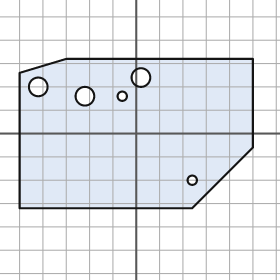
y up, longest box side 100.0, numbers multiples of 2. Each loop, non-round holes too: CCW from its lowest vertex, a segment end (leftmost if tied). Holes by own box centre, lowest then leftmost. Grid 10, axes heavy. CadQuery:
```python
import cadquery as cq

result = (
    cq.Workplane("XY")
    .moveTo(-50.0, -32.0)
    .lineTo(24.0, -32.0)
    .lineTo(50.0, -6.0)
    .lineTo(50.0, 32.0)
    .lineTo(-30.0, 32.0)
    .lineTo(-50.0, 26.0)
    .close()
    .moveTo(24.0, -20.0)
    .circle(2.0)
    .moveTo(-22.0, 16.0)
    .circle(4.0)
    .moveTo(-6.0, 16.0)
    .circle(2.0)
    .moveTo(-42.0, 20.0)
    .circle(4.0)
    .moveTo(2.0, 24.0)
    .circle(4.0)
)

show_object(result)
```